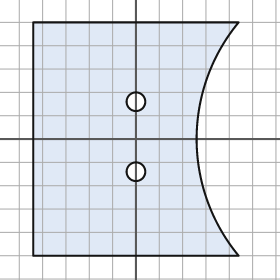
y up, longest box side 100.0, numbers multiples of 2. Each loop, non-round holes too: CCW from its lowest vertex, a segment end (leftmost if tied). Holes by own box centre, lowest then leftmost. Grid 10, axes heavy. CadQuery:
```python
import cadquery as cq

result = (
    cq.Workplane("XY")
    .moveTo(-44.0, -50.0)
    .lineTo(44.0, -50.0)
    .threePointArc((26.0, 0.0), (44.0, 50.0))
    .lineTo(-44.0, 50.0)
    .close()
    .moveTo(0.0, -14.0)
    .circle(4.0)
    .moveTo(0.0, 16.0)
    .circle(4.0)
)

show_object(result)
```